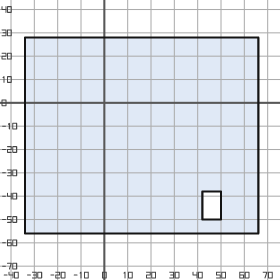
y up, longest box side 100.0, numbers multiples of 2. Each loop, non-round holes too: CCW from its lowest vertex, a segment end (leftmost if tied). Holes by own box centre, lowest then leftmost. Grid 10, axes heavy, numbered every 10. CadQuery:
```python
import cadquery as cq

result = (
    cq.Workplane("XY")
    .moveTo(-34.0, -56.0)
    .lineTo(66.0, -56.0)
    .lineTo(66.0, 28.0)
    .lineTo(-34.0, 28.0)
    .close()
    .moveTo(42.0, -50.0)
    .lineTo(50.0, -50.0)
    .lineTo(50.0, -38.0)
    .lineTo(42.0, -38.0)
    .close()
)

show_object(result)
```